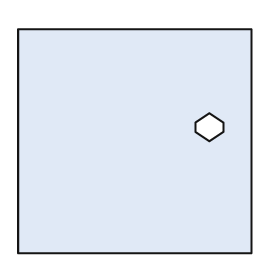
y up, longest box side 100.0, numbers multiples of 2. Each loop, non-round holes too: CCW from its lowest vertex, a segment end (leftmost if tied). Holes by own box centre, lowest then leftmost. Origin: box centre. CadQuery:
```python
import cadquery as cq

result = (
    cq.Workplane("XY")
    .moveTo(-50.0, -48.0)
    .lineTo(50.0, -48.0)
    .lineTo(50.0, 48.0)
    .lineTo(-50.0, 48.0)
    .close()
    .moveTo(32.0, 0.0)
    .lineTo(38.0, 4.0)
    .lineTo(38.0, 8.0)
    .lineTo(32.0, 12.0)
    .lineTo(26.0, 8.0)
    .lineTo(26.0, 4.0)
    .close()
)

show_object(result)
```